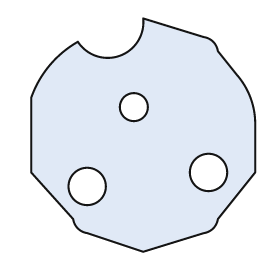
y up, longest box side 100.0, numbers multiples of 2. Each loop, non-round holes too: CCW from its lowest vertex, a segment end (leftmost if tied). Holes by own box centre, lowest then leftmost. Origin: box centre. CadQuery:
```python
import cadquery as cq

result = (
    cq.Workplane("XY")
    .moveTo(0.0, -50.0)
    .lineTo(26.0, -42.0)
    .threePointArc((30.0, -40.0), (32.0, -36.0))
    .lineTo(48.0, -16.0)
    .lineTo(48.0, 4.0)
    .threePointArc((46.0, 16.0), (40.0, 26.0))
    .lineTo(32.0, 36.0)
    .threePointArc((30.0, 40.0), (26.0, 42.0))
    .lineTo(0.0, 50.0)
    .threePointArc((-10.0, 34.0), (-28.0, 40.0))
    .threePointArc((-40.0, 30.0), (-48.0, 16.0))
    .lineTo(-48.0, -16.0)
    .lineTo(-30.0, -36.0)
    .threePointArc((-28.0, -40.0), (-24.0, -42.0))
    .close()
    .moveTo(-24.0, -22.0)
    .circle(8.0)
    .moveTo(28.0, -16.0)
    .circle(8.0)
    .moveTo(-4.0, 12.0)
    .circle(6.0)
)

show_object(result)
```